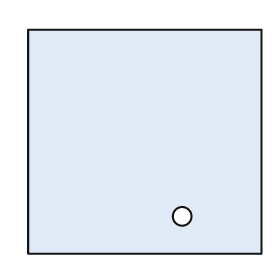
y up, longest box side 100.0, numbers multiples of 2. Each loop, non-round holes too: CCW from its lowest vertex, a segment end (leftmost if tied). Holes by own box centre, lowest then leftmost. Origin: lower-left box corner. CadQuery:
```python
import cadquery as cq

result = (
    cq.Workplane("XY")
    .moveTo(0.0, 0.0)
    .lineTo(100.0, 0.0)
    .lineTo(100.0, 96.0)
    .lineTo(0.0, 96.0)
    .close()
    .moveTo(66.0, 16.0)
    .circle(4.0)
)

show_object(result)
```